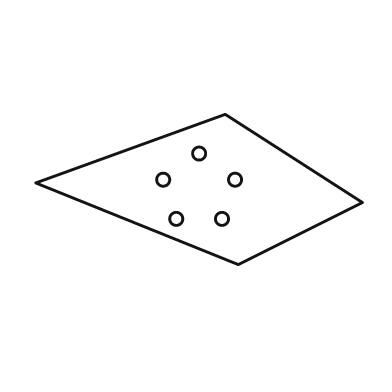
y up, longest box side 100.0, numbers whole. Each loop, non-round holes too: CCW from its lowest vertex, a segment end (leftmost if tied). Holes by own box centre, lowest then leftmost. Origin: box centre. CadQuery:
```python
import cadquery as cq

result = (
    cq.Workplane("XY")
    .moveTo(12.0, -23.0)
    .lineTo(50.0, -4.0)
    .lineTo(8.0, 23.0)
    .lineTo(-50.0, 2.0)
    .close()
    .moveTo(-7.0, -9.0)
    .circle(2.0)
    .moveTo(7.0, -9.0)
    .circle(2.0)
    .moveTo(-11.0, 3.0)
    .circle(2.0)
    .moveTo(11.0, 3.0)
    .circle(2.0)
    .moveTo(0.0, 11.0)
    .circle(2.0)
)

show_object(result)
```